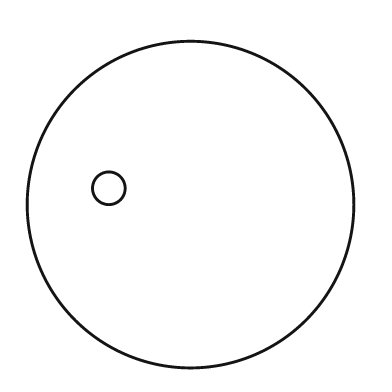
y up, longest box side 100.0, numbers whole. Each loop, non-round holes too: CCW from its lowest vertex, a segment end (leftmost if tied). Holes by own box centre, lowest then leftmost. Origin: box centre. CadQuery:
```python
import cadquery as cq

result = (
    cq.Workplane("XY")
    .moveTo(0.0, 0.0)
    .circle(50.0)
    .moveTo(-25.0, 5.0)
    .circle(5.0)
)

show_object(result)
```